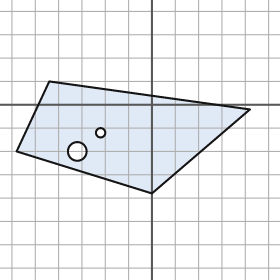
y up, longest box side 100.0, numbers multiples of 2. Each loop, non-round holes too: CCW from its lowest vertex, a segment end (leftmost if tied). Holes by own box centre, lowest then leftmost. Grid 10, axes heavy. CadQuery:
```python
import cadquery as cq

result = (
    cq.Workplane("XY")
    .moveTo(0.0, -38.0)
    .lineTo(42.0, -2.0)
    .lineTo(-44.0, 10.0)
    .lineTo(-58.0, -20.0)
    .close()
    .moveTo(-32.0, -20.0)
    .circle(4.0)
    .moveTo(-22.0, -12.0)
    .circle(2.0)
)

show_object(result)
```